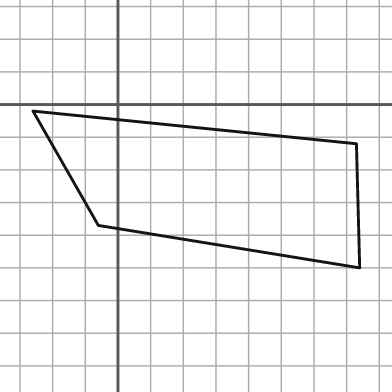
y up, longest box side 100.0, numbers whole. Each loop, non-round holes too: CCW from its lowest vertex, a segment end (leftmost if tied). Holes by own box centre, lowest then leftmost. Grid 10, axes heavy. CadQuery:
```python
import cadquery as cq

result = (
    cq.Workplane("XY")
    .moveTo(74.0, -50.0)
    .lineTo(73.0, -12.0)
    .lineTo(-26.0, -2.0)
    .lineTo(-6.0, -37.0)
    .close()
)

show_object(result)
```